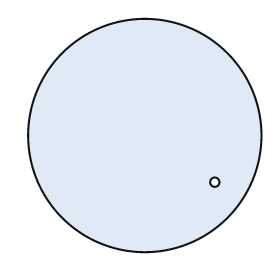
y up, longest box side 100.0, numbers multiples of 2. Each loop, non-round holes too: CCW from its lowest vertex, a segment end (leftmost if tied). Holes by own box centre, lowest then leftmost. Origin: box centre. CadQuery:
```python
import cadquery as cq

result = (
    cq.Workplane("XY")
    .moveTo(0.0, 0.0)
    .circle(50.0)
    .moveTo(30.0, -20.0)
    .circle(2.0)
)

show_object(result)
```